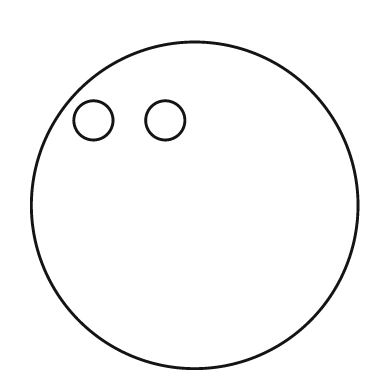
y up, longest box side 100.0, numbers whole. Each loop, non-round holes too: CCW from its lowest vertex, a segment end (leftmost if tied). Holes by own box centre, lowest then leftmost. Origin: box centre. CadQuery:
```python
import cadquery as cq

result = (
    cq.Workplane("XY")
    .moveTo(0.0, 0.0)
    .circle(50.0)
    .moveTo(-31.0, 26.0)
    .circle(6.0)
    .moveTo(-9.0, 26.0)
    .circle(6.0)
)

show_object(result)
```